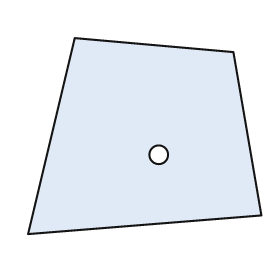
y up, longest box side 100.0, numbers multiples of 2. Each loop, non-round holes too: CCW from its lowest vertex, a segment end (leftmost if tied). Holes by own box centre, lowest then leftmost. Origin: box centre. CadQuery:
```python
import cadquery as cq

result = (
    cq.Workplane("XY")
    .moveTo(-50.0, -42.0)
    .lineTo(50.0, -34.0)
    .lineTo(38.0, 36.0)
    .lineTo(-30.0, 42.0)
    .close()
    .moveTo(6.0, -8.0)
    .circle(4.0)
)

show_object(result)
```